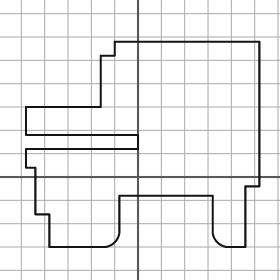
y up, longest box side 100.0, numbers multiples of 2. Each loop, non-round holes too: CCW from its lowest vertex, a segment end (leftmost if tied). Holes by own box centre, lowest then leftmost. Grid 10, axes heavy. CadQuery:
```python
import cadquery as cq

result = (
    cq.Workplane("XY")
    .moveTo(-38.0, -30.0)
    .lineTo(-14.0, -30.0)
    .threePointArc((-10.0, -28.0), (-8.0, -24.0))
    .lineTo(-8.0, -8.0)
    .lineTo(32.0, -8.0)
    .lineTo(32.0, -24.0)
    .threePointArc((34.0, -28.0), (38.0, -30.0))
    .lineTo(46.0, -30.0)
    .lineTo(46.0, -4.0)
    .lineTo(52.0, -4.0)
    .lineTo(52.0, 58.0)
    .lineTo(-10.0, 58.0)
    .lineTo(-10.0, 52.0)
    .lineTo(-16.0, 52.0)
    .lineTo(-16.0, 30.0)
    .lineTo(-48.0, 30.0)
    .lineTo(-48.0, 18.0)
    .lineTo(0.0, 18.0)
    .lineTo(0.0, 12.0)
    .lineTo(-48.0, 12.0)
    .lineTo(-48.0, 4.0)
    .lineTo(-44.0, 4.0)
    .lineTo(-44.0, -16.0)
    .lineTo(-38.0, -16.0)
    .close()
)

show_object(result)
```